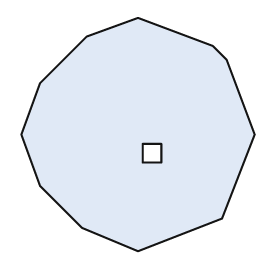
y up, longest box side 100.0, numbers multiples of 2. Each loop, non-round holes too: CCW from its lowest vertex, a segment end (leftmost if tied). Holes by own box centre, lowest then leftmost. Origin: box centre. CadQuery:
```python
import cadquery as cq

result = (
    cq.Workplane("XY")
    .moveTo(0.0, -50.0)
    .lineTo(36.0, -36.0)
    .lineTo(50.0, 0.0)
    .lineTo(38.0, 32.0)
    .lineTo(32.0, 38.0)
    .lineTo(0.0, 50.0)
    .lineTo(-22.0, 42.0)
    .lineTo(-42.0, 22.0)
    .lineTo(-50.0, 0.0)
    .lineTo(-42.0, -22.0)
    .lineTo(-24.0, -40.0)
    .close()
    .moveTo(2.0, -12.0)
    .lineTo(10.0, -12.0)
    .lineTo(10.0, -4.0)
    .lineTo(2.0, -4.0)
    .close()
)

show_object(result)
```